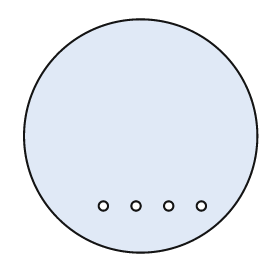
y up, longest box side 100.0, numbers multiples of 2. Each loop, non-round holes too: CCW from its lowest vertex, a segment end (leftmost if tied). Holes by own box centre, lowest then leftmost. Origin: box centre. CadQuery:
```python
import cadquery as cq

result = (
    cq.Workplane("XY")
    .moveTo(0.0, 0.0)
    .circle(50.0)
    .moveTo(-16.0, -30.0)
    .circle(2.0)
    .moveTo(-2.0, -30.0)
    .circle(2.0)
    .moveTo(12.0, -30.0)
    .circle(2.0)
    .moveTo(26.0, -30.0)
    .circle(2.0)
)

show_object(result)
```